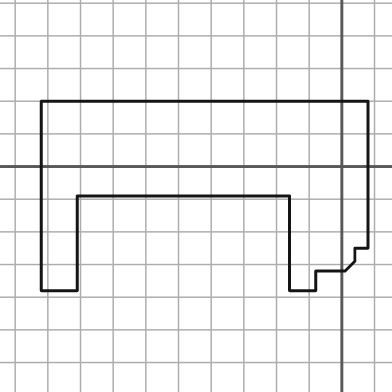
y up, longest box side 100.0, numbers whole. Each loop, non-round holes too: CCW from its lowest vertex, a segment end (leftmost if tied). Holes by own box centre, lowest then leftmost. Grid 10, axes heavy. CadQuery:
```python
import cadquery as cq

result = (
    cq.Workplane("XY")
    .moveTo(-92.0, -38.0)
    .lineTo(-81.0, -38.0)
    .lineTo(-81.0, -9.0)
    .lineTo(-16.0, -9.0)
    .lineTo(-16.0, -38.0)
    .lineTo(-8.0, -38.0)
    .lineTo(-8.0, -32.0)
    .lineTo(1.0, -32.0)
    .lineTo(4.0, -29.0)
    .lineTo(4.0, -25.0)
    .lineTo(8.0, -25.0)
    .lineTo(8.0, 20.0)
    .lineTo(-92.0, 20.0)
    .close()
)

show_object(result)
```